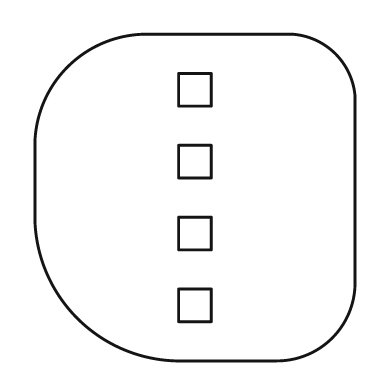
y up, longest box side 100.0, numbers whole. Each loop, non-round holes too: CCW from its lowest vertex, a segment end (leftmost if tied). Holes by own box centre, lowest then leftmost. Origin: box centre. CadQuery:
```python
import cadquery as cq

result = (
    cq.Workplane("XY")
    .moveTo(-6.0, -50.0)
    .lineTo(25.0, -50.0)
    .threePointArc((42.0, -43.0), (49.0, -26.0))
    .lineTo(49.0, 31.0)
    .threePointArc((43.0, 44.0), (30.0, 50.0))
    .lineTo(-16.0, 50.0)
    .threePointArc((-39.0, 40.0), (-49.0, 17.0))
    .lineTo(-49.0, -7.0)
    .threePointArc((-36.0, -37.0), (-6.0, -50.0))
    .close()
    .moveTo(-5.0, -38.0)
    .lineTo(5.0, -38.0)
    .lineTo(5.0, -28.0)
    .lineTo(-5.0, -28.0)
    .close()
    .moveTo(-5.0, -16.0)
    .lineTo(5.0, -16.0)
    .lineTo(5.0, -6.0)
    .lineTo(-5.0, -6.0)
    .close()
    .moveTo(-5.0, 6.0)
    .lineTo(5.0, 6.0)
    .lineTo(5.0, 16.0)
    .lineTo(-5.0, 16.0)
    .close()
    .moveTo(-5.0, 28.0)
    .lineTo(5.0, 28.0)
    .lineTo(5.0, 38.0)
    .lineTo(-5.0, 38.0)
    .close()
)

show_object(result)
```